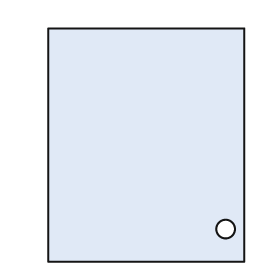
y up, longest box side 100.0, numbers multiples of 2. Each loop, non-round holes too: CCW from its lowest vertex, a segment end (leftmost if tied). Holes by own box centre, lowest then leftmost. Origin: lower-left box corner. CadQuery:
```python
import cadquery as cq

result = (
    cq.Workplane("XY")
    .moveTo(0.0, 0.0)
    .lineTo(84.0, 0.0)
    .lineTo(84.0, 100.0)
    .lineTo(0.0, 100.0)
    .close()
    .moveTo(76.0, 14.0)
    .circle(4.0)
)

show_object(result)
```